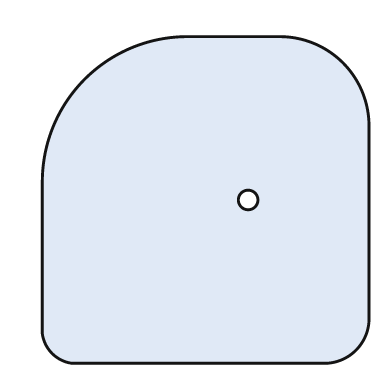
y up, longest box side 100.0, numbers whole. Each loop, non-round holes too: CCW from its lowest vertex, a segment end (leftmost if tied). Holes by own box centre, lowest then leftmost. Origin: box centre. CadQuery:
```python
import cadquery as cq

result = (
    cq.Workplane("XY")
    .moveTo(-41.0, -50.0)
    .lineTo(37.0, -50.0)
    .threePointArc((46.0, -46.0), (50.0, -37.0))
    .lineTo(50.0, 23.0)
    .threePointArc((42.0, 42.0), (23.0, 50.0))
    .lineTo(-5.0, 50.0)
    .threePointArc((-37.0, 37.0), (-50.0, 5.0))
    .lineTo(-50.0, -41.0)
    .threePointArc((-47.0, -47.0), (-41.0, -50.0))
    .close()
    .moveTo(13.0, 0.0)
    .circle(3.0)
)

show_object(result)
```